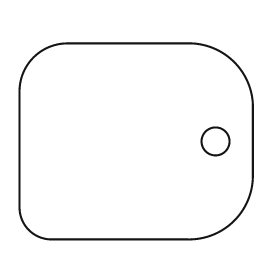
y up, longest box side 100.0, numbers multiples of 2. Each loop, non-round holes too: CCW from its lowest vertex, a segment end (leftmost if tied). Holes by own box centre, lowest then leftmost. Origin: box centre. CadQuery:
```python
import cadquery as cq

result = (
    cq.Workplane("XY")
    .moveTo(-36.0, -42.0)
    .lineTo(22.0, -42.0)
    .threePointArc((42.0, -34.0), (50.0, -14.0))
    .lineTo(50.0, 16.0)
    .threePointArc((42.0, 34.0), (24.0, 42.0))
    .lineTo(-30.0, 42.0)
    .threePointArc((-44.0, 36.0), (-50.0, 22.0))
    .lineTo(-50.0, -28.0)
    .threePointArc((-46.0, -38.0), (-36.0, -42.0))
    .close()
    .moveTo(34.0, 0.0)
    .circle(6.0)
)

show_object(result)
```